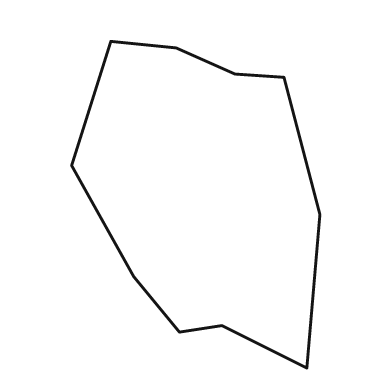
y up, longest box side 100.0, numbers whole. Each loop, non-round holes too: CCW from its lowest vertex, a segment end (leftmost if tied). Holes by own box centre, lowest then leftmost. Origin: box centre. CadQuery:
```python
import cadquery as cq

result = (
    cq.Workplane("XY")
    .moveTo(34.0, -50.0)
    .lineTo(38.0, -3.0)
    .lineTo(27.0, 39.0)
    .lineTo(12.0, 40.0)
    .lineTo(-6.0, 48.0)
    .lineTo(-26.0, 50.0)
    .lineTo(-38.0, 12.0)
    .lineTo(-19.0, -22.0)
    .lineTo(-5.0, -39.0)
    .lineTo(8.0, -37.0)
    .close()
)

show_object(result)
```